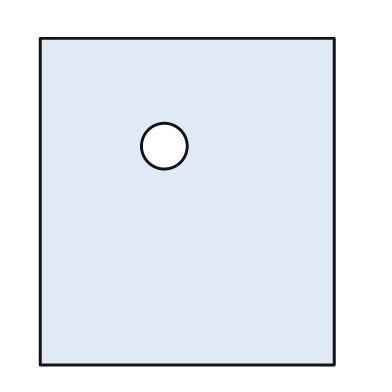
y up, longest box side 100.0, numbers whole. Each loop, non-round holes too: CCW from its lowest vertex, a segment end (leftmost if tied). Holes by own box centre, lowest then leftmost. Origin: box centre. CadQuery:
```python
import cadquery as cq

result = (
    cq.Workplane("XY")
    .moveTo(-45.0, -50.0)
    .lineTo(45.0, -50.0)
    .lineTo(45.0, 50.0)
    .lineTo(-45.0, 50.0)
    .close()
    .moveTo(-7.0, 17.0)
    .circle(7.0)
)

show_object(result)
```